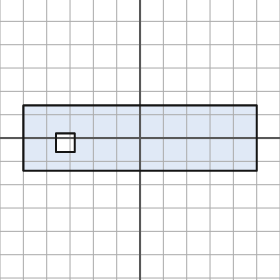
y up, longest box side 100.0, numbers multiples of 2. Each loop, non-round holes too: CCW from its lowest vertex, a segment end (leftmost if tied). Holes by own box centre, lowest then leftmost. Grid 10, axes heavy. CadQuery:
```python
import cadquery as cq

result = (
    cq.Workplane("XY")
    .moveTo(-50.0, -14.0)
    .lineTo(50.0, -14.0)
    .lineTo(50.0, 14.0)
    .lineTo(-50.0, 14.0)
    .close()
    .moveTo(-36.0, -6.0)
    .lineTo(-28.0, -6.0)
    .lineTo(-28.0, 2.0)
    .lineTo(-36.0, 2.0)
    .close()
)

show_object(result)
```